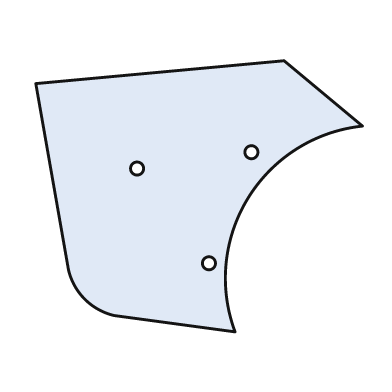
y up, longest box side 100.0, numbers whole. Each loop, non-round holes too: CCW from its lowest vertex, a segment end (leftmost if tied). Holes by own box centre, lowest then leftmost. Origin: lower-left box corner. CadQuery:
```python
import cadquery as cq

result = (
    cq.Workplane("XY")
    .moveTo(61.0, 0.0)
    .threePointArc((65.0, 41.0), (100.0, 63.0))
    .lineTo(76.0, 83.0)
    .lineTo(0.0, 76.0)
    .lineTo(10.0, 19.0)
    .threePointArc((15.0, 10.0), (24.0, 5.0))
    .close()
    .moveTo(53.0, 21.0)
    .circle(2.0)
    .moveTo(31.0, 50.0)
    .circle(2.0)
    .moveTo(66.0, 55.0)
    .circle(2.0)
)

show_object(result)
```